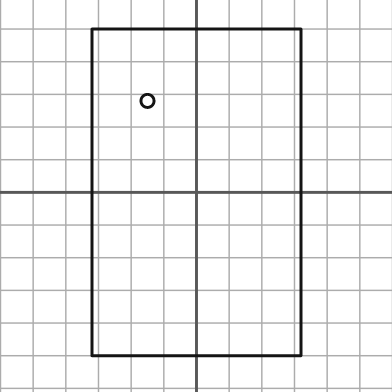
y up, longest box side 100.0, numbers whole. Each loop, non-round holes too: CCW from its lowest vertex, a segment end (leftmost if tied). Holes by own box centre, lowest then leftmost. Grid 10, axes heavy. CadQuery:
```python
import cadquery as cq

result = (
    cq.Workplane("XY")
    .moveTo(-32.0, -50.0)
    .lineTo(32.0, -50.0)
    .lineTo(32.0, 50.0)
    .lineTo(-32.0, 50.0)
    .close()
    .moveTo(-15.0, 28.0)
    .circle(2.0)
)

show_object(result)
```